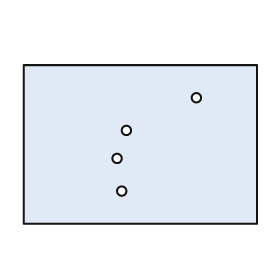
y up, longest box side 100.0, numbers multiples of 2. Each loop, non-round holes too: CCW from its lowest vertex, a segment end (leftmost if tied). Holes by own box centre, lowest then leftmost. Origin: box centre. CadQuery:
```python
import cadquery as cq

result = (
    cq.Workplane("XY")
    .moveTo(-50.0, -34.0)
    .lineTo(50.0, -34.0)
    .lineTo(50.0, 34.0)
    .lineTo(-50.0, 34.0)
    .close()
    .moveTo(-8.0, -20.0)
    .circle(2.0)
    .moveTo(-10.0, -6.0)
    .circle(2.0)
    .moveTo(-6.0, 6.0)
    .circle(2.0)
    .moveTo(24.0, 20.0)
    .circle(2.0)
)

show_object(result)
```